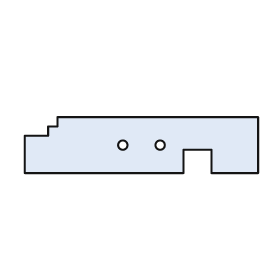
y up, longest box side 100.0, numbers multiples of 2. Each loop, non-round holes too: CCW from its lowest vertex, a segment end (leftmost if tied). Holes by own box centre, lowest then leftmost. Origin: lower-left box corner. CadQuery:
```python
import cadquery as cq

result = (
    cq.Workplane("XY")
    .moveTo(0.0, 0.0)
    .lineTo(68.0, 0.0)
    .lineTo(68.0, 10.0)
    .lineTo(80.0, 10.0)
    .lineTo(80.0, 0.0)
    .lineTo(100.0, 0.0)
    .lineTo(100.0, 24.0)
    .lineTo(14.0, 24.0)
    .lineTo(14.0, 20.0)
    .lineTo(10.0, 20.0)
    .lineTo(10.0, 16.0)
    .lineTo(0.0, 16.0)
    .close()
    .moveTo(42.0, 12.0)
    .circle(2.0)
    .moveTo(58.0, 12.0)
    .circle(2.0)
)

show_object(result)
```